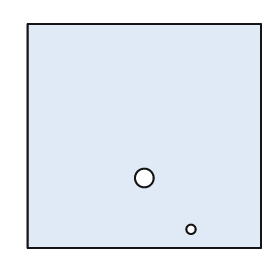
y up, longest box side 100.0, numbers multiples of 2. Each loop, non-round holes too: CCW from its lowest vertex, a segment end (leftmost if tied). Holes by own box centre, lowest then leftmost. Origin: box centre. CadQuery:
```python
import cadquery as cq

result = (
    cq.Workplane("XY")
    .moveTo(-50.0, -48.0)
    .lineTo(50.0, -48.0)
    .lineTo(50.0, 48.0)
    .lineTo(-50.0, 48.0)
    .close()
    .moveTo(20.0, -40.0)
    .circle(2.0)
    .moveTo(0.0, -18.0)
    .circle(4.0)
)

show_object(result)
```